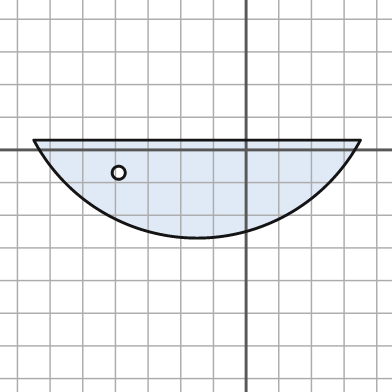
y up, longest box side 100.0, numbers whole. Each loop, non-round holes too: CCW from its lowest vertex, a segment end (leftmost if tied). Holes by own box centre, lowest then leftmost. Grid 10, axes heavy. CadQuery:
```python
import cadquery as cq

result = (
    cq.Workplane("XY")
    .moveTo(-65.0, 3.0)
    .threePointArc((-15.0, -27.0), (35.0, 3.0))
    .close()
    .moveTo(-39.0, -7.0)
    .circle(2.0)
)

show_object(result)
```